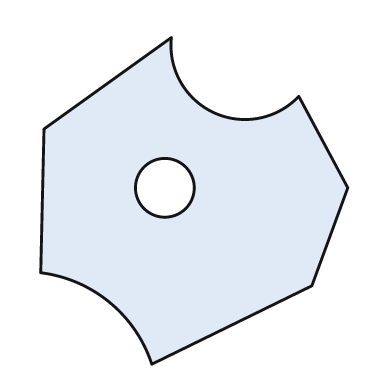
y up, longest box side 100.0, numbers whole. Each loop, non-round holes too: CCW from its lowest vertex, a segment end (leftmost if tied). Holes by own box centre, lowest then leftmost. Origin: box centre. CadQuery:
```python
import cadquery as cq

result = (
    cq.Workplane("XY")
    .moveTo(-13.0, -50.0)
    .lineTo(36.0, -26.0)
    .lineTo(47.0, 4.0)
    .lineTo(32.0, 32.0)
    .threePointArc((6.0, 27.0), (-7.0, 50.0))
    .lineTo(-46.0, 22.0)
    .lineTo(-47.0, -22.0)
    .threePointArc((-26.0, -31.0), (-13.0, -50.0))
    .close()
    .moveTo(-9.0, 4.0)
    .circle(9.0)
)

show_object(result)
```